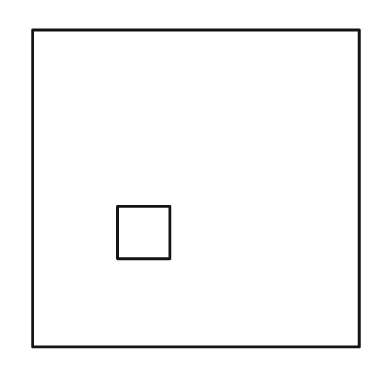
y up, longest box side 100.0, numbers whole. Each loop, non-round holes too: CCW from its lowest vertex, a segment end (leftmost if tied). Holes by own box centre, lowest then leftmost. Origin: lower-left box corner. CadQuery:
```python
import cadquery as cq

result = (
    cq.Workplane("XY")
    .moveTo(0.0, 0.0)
    .lineTo(100.0, 0.0)
    .lineTo(100.0, 97.0)
    .lineTo(0.0, 97.0)
    .close()
    .moveTo(26.0, 27.0)
    .lineTo(42.0, 27.0)
    .lineTo(42.0, 43.0)
    .lineTo(26.0, 43.0)
    .close()
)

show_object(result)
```